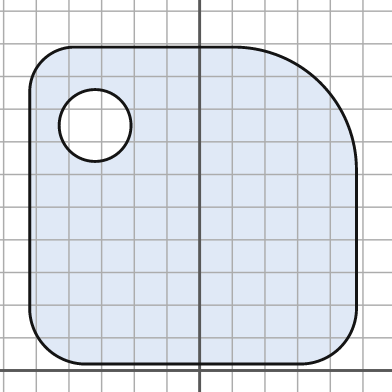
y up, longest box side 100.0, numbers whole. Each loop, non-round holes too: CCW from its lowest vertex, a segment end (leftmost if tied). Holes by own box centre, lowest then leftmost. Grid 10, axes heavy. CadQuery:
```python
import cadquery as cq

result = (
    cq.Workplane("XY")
    .moveTo(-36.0, 2.0)
    .lineTo(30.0, 2.0)
    .threePointArc((43.0, 7.0), (48.0, 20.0))
    .lineTo(48.0, 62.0)
    .threePointArc((37.0, 88.0), (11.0, 99.0))
    .lineTo(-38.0, 99.0)
    .threePointArc((-48.0, 95.0), (-52.0, 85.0))
    .lineTo(-52.0, 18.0)
    .threePointArc((-47.0, 7.0), (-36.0, 2.0))
    .close()
    .moveTo(-32.0, 75.0)
    .circle(11.0)
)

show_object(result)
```